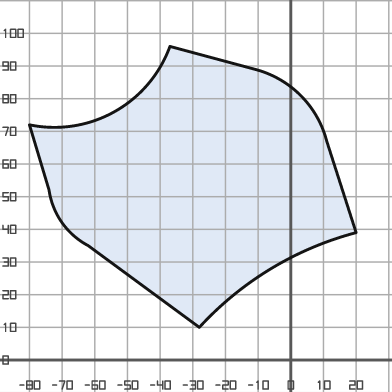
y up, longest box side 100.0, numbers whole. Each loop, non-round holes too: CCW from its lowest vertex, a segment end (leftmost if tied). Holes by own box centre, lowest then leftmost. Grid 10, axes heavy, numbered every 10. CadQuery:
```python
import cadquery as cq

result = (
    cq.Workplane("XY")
    .moveTo(-28.0, 10.0)
    .threePointArc((-6.0, 28.0), (20.0, 39.0))
    .lineTo(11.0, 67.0)
    .threePointArc((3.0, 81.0), (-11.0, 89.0))
    .lineTo(-37.0, 96.0)
    .threePointArc((-54.0, 76.0), (-80.0, 72.0))
    .lineTo(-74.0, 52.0)
    .threePointArc((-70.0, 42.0), (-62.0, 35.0))
    .close()
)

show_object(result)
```